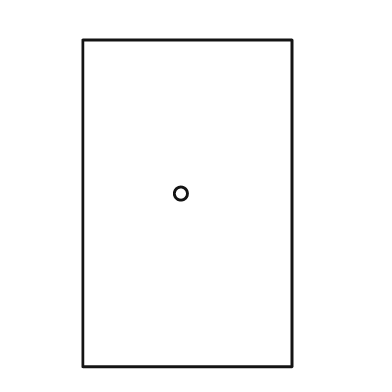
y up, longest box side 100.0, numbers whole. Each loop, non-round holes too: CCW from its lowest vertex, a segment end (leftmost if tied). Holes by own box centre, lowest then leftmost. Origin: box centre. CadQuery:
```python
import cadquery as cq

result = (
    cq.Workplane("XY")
    .moveTo(-32.0, -50.0)
    .lineTo(32.0, -50.0)
    .lineTo(32.0, 50.0)
    .lineTo(-32.0, 50.0)
    .close()
    .moveTo(-2.0, 3.0)
    .circle(2.0)
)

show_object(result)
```